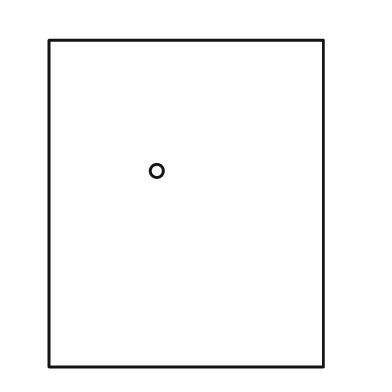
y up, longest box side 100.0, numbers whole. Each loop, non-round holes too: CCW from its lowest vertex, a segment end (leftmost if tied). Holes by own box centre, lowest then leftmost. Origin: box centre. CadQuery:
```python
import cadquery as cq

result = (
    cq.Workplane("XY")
    .moveTo(-42.0, -50.0)
    .lineTo(42.0, -50.0)
    .lineTo(42.0, 50.0)
    .lineTo(-42.0, 50.0)
    .close()
    .moveTo(-9.0, 10.0)
    .circle(2.0)
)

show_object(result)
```